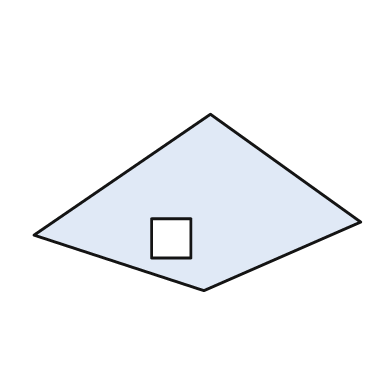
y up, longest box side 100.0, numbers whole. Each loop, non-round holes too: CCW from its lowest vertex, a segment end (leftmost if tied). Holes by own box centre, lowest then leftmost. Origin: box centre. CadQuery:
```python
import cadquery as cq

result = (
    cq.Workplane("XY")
    .moveTo(2.0, -27.0)
    .lineTo(50.0, -6.0)
    .lineTo(4.0, 27.0)
    .lineTo(-50.0, -10.0)
    .close()
    .moveTo(-14.0, -17.0)
    .lineTo(-2.0, -17.0)
    .lineTo(-2.0, -5.0)
    .lineTo(-14.0, -5.0)
    .close()
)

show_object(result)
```